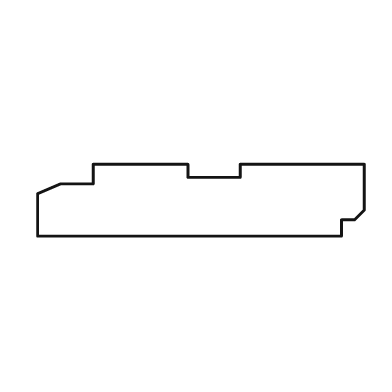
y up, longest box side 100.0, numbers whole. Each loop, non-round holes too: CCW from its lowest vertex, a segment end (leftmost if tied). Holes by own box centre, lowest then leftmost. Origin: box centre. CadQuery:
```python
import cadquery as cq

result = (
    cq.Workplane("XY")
    .moveTo(-50.0, -11.0)
    .lineTo(43.0, -11.0)
    .lineTo(43.0, -6.0)
    .lineTo(47.0, -6.0)
    .lineTo(50.0, -3.0)
    .lineTo(50.0, 11.0)
    .lineTo(12.0, 11.0)
    .lineTo(12.0, 7.0)
    .lineTo(-4.0, 7.0)
    .lineTo(-4.0, 11.0)
    .lineTo(-33.0, 11.0)
    .lineTo(-33.0, 5.0)
    .lineTo(-43.0, 5.0)
    .lineTo(-50.0, 2.0)
    .close()
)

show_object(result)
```